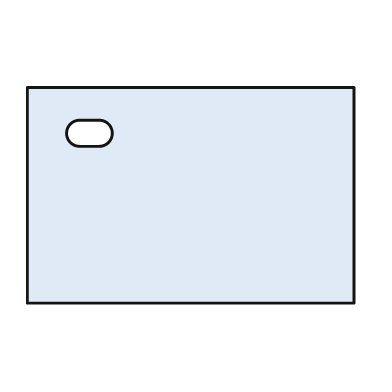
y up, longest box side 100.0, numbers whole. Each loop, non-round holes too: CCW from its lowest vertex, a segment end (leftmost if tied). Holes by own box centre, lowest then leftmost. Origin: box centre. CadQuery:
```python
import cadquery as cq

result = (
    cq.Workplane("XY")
    .moveTo(-50.0, -33.0)
    .lineTo(50.0, -33.0)
    .lineTo(50.0, 33.0)
    .lineTo(-50.0, 33.0)
    .close()
    .moveTo(-34.0, 15.0)
    .lineTo(-28.0, 15.0)
    .threePointArc((-24.0, 19.0), (-28.0, 23.0))
    .lineTo(-34.0, 23.0)
    .threePointArc((-38.0, 19.0), (-34.0, 15.0))
    .close()
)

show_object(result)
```